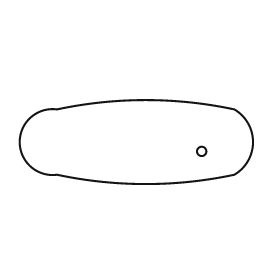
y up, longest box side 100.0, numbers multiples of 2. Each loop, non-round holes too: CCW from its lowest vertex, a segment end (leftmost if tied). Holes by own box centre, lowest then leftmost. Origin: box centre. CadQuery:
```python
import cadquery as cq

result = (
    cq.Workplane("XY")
    .moveTo(-34.0, -14.0)
    .threePointArc((4.0, -18.0), (42.0, -14.0))
    .threePointArc((50.0, 0.0), (42.0, 14.0))
    .threePointArc((4.0, 18.0), (-34.0, 14.0))
    .threePointArc((-50.0, 0.0), (-34.0, -14.0))
    .close()
    .moveTo(28.0, -4.0)
    .circle(2.0)
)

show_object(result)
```